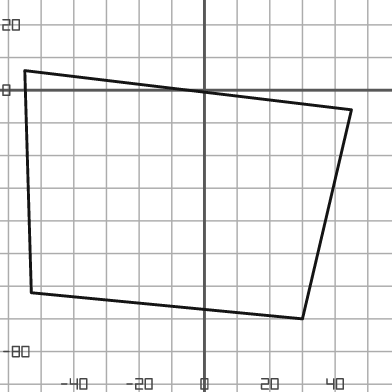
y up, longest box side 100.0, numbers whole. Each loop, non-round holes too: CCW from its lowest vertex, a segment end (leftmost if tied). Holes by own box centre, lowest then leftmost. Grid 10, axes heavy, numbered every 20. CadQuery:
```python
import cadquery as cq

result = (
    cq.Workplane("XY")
    .moveTo(30.0, -70.0)
    .lineTo(45.0, -6.0)
    .lineTo(-55.0, 6.0)
    .lineTo(-53.0, -62.0)
    .close()
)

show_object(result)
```